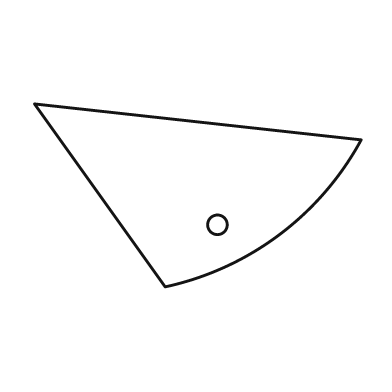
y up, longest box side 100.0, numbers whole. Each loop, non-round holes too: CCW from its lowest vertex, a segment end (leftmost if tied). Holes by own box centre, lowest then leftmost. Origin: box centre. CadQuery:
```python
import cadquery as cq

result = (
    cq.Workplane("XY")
    .moveTo(-10.0, -28.0)
    .threePointArc((25.0, -12.0), (50.0, 17.0))
    .lineTo(-50.0, 28.0)
    .close()
    .moveTo(6.0, -9.0)
    .circle(3.0)
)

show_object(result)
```